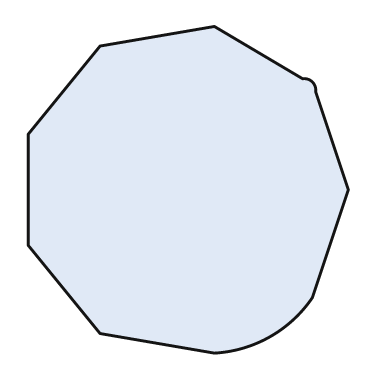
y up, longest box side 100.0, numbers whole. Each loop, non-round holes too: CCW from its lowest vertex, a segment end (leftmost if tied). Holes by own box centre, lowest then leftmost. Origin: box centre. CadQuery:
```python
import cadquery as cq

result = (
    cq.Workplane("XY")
    .moveTo(8.0, -50.0)
    .threePointArc((25.0, -45.0), (38.0, -33.0))
    .lineTo(49.0, 0.0)
    .lineTo(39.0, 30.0)
    .threePointArc((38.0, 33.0), (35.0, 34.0))
    .lineTo(8.0, 50.0)
    .lineTo(-27.0, 44.0)
    .lineTo(-49.0, 17.0)
    .lineTo(-49.0, -17.0)
    .lineTo(-27.0, -44.0)
    .close()
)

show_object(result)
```